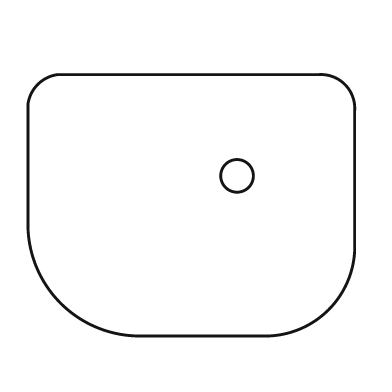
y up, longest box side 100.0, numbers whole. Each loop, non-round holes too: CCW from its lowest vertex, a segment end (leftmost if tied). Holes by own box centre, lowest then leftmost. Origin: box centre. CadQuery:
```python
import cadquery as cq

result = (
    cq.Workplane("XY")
    .moveTo(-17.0, -40.0)
    .lineTo(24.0, -40.0)
    .threePointArc((42.0, -32.0), (50.0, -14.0))
    .lineTo(50.0, 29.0)
    .threePointArc((47.0, 37.0), (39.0, 40.0))
    .lineTo(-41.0, 40.0)
    .threePointArc((-47.0, 37.0), (-50.0, 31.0))
    .lineTo(-50.0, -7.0)
    .threePointArc((-40.0, -30.0), (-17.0, -40.0))
    .close()
    .moveTo(14.0, 9.0)
    .circle(5.0)
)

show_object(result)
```